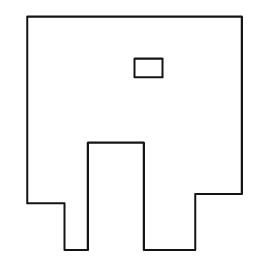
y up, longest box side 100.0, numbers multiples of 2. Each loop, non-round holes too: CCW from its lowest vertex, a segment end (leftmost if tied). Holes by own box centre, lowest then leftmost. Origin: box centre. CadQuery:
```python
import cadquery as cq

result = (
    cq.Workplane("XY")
    .moveTo(-30.0, -50.0)
    .lineTo(-20.0, -50.0)
    .lineTo(-20.0, -4.0)
    .lineTo(4.0, -4.0)
    .lineTo(4.0, -50.0)
    .lineTo(26.0, -50.0)
    .lineTo(26.0, -26.0)
    .lineTo(46.0, -26.0)
    .lineTo(46.0, 50.0)
    .lineTo(-46.0, 50.0)
    .lineTo(-46.0, -30.0)
    .lineTo(-30.0, -30.0)
    .close()
    .moveTo(0.0, 24.0)
    .lineTo(12.0, 24.0)
    .lineTo(12.0, 32.0)
    .lineTo(0.0, 32.0)
    .close()
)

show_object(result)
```